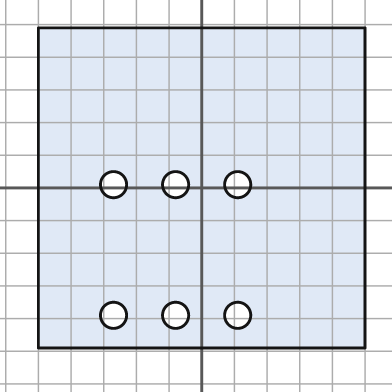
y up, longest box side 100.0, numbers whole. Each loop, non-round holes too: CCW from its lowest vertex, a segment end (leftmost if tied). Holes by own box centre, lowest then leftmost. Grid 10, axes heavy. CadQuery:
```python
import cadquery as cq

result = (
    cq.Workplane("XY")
    .moveTo(-50.0, -49.0)
    .lineTo(50.0, -49.0)
    .lineTo(50.0, 49.0)
    .lineTo(-50.0, 49.0)
    .close()
    .moveTo(-27.0, -39.0)
    .circle(4.0)
    .moveTo(-8.0, -39.0)
    .circle(4.0)
    .moveTo(11.0, -39.0)
    .circle(4.0)
    .moveTo(-27.0, 1.0)
    .circle(4.0)
    .moveTo(-8.0, 1.0)
    .circle(4.0)
    .moveTo(11.0, 1.0)
    .circle(4.0)
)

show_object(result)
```